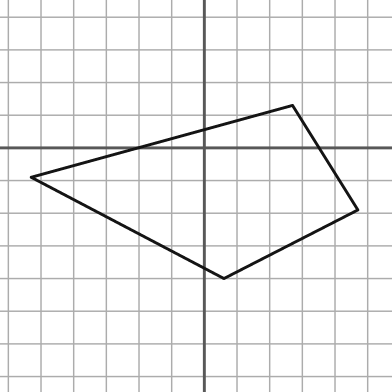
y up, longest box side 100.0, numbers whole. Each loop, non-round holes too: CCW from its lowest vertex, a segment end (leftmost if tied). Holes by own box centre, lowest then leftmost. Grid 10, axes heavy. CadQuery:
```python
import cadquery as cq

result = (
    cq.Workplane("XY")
    .moveTo(6.0, -40.0)
    .lineTo(47.0, -19.0)
    .lineTo(27.0, 13.0)
    .lineTo(-53.0, -9.0)
    .close()
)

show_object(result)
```